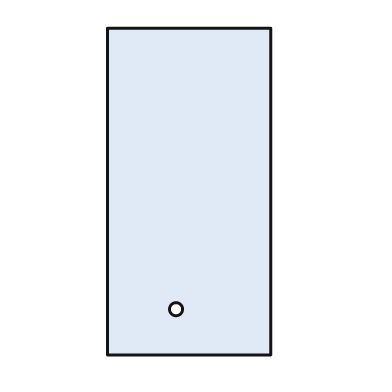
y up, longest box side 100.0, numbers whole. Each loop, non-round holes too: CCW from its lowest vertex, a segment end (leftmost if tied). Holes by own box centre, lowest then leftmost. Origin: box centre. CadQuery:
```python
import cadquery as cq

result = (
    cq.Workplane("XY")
    .moveTo(-25.0, -50.0)
    .lineTo(25.0, -50.0)
    .lineTo(25.0, 50.0)
    .lineTo(-25.0, 50.0)
    .close()
    .moveTo(-4.0, -36.0)
    .circle(2.0)
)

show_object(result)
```